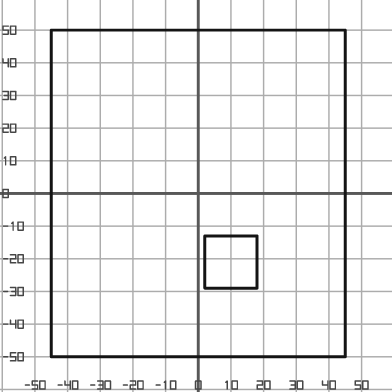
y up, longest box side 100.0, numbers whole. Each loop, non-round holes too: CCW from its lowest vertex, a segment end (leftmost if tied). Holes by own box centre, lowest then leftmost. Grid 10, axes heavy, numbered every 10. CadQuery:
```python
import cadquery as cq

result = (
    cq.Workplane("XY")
    .moveTo(-45.0, -50.0)
    .lineTo(45.0, -50.0)
    .lineTo(45.0, 50.0)
    .lineTo(-45.0, 50.0)
    .close()
    .moveTo(2.0, -29.0)
    .lineTo(18.0, -29.0)
    .lineTo(18.0, -13.0)
    .lineTo(2.0, -13.0)
    .close()
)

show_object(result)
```